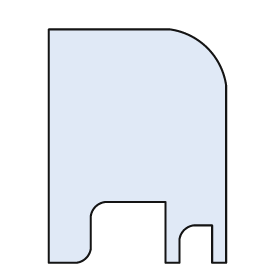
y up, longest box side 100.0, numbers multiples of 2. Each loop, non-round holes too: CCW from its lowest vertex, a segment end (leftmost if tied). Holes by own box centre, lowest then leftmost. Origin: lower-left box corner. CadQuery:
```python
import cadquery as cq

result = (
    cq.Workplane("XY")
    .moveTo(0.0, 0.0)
    .lineTo(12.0, 0.0)
    .threePointArc((16.0, 2.0), (18.0, 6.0))
    .lineTo(18.0, 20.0)
    .threePointArc((20.0, 24.0), (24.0, 26.0))
    .lineTo(50.0, 26.0)
    .lineTo(50.0, 0.0)
    .lineTo(56.0, 0.0)
    .lineTo(56.0, 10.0)
    .threePointArc((58.0, 14.0), (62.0, 16.0))
    .lineTo(70.0, 16.0)
    .lineTo(70.0, 0.0)
    .lineTo(76.0, 0.0)
    .lineTo(76.0, 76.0)
    .threePointArc((68.0, 92.0), (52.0, 100.0))
    .lineTo(0.0, 100.0)
    .close()
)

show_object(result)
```